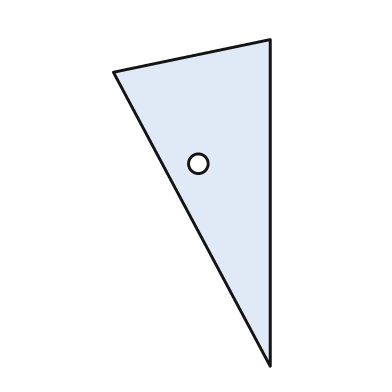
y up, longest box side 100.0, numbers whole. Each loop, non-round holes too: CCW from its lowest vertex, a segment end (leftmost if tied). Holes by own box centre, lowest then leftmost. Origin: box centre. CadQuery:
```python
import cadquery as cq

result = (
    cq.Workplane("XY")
    .moveTo(24.0, -50.0)
    .lineTo(24.0, 50.0)
    .lineTo(-24.0, 40.0)
    .close()
    .moveTo(2.0, 12.0)
    .circle(3.0)
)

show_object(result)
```